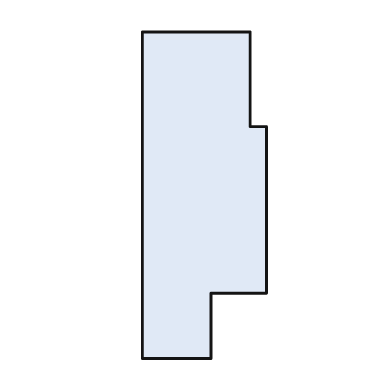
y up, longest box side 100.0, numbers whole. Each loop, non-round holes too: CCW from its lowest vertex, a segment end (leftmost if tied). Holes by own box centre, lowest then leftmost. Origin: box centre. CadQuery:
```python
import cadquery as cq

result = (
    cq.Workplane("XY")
    .moveTo(-19.0, -50.0)
    .lineTo(2.0, -50.0)
    .lineTo(2.0, -30.0)
    .lineTo(19.0, -30.0)
    .lineTo(19.0, 21.0)
    .lineTo(14.0, 21.0)
    .lineTo(14.0, 50.0)
    .lineTo(-19.0, 50.0)
    .close()
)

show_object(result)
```